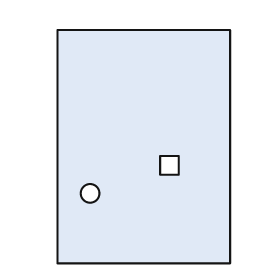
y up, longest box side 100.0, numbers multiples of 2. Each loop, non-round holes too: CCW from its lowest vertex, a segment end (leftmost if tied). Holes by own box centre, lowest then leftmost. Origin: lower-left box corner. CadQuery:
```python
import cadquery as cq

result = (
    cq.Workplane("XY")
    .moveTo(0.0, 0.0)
    .lineTo(74.0, 0.0)
    .lineTo(74.0, 100.0)
    .lineTo(0.0, 100.0)
    .close()
    .moveTo(14.0, 30.0)
    .circle(4.0)
    .moveTo(44.0, 38.0)
    .lineTo(52.0, 38.0)
    .lineTo(52.0, 46.0)
    .lineTo(44.0, 46.0)
    .close()
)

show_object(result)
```